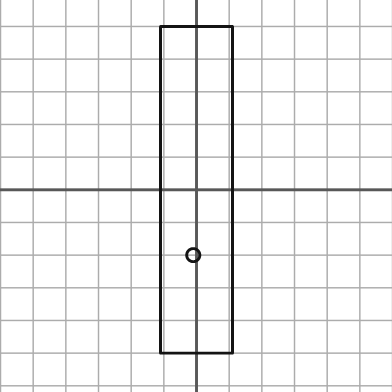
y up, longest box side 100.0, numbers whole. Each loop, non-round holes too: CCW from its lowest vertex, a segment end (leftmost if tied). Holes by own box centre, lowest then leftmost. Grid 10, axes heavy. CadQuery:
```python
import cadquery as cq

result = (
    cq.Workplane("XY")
    .moveTo(-11.0, -50.0)
    .lineTo(11.0, -50.0)
    .lineTo(11.0, 50.0)
    .lineTo(-11.0, 50.0)
    .close()
    .moveTo(-1.0, -20.0)
    .circle(2.0)
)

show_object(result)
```